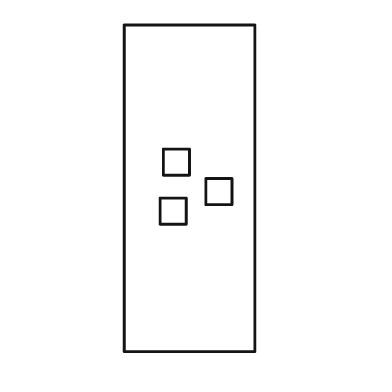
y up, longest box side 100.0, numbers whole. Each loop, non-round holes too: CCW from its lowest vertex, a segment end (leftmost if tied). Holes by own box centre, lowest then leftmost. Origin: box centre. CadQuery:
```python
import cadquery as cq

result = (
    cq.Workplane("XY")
    .moveTo(-20.0, -50.0)
    .lineTo(20.0, -50.0)
    .lineTo(20.0, 50.0)
    .lineTo(-20.0, 50.0)
    .close()
    .moveTo(-9.0, -11.0)
    .lineTo(-1.0, -11.0)
    .lineTo(-1.0, -3.0)
    .lineTo(-9.0, -3.0)
    .close()
    .moveTo(5.0, -5.0)
    .lineTo(13.0, -5.0)
    .lineTo(13.0, 3.0)
    .lineTo(5.0, 3.0)
    .close()
    .moveTo(-8.0, 4.0)
    .lineTo(0.0, 4.0)
    .lineTo(0.0, 12.0)
    .lineTo(-8.0, 12.0)
    .close()
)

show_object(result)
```